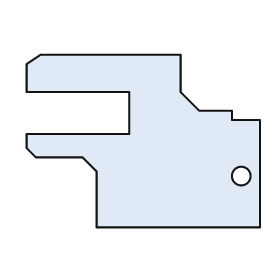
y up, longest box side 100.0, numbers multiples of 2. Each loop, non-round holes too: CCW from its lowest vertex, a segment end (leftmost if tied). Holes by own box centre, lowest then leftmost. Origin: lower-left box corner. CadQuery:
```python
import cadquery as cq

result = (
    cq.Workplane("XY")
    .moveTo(30.0, 0.0)
    .lineTo(100.0, 0.0)
    .lineTo(100.0, 46.0)
    .lineTo(88.0, 46.0)
    .lineTo(88.0, 50.0)
    .lineTo(74.0, 50.0)
    .lineTo(66.0, 58.0)
    .lineTo(66.0, 74.0)
    .lineTo(6.0, 74.0)
    .lineTo(0.0, 70.0)
    .lineTo(0.0, 58.0)
    .lineTo(44.0, 58.0)
    .lineTo(44.0, 40.0)
    .lineTo(0.0, 40.0)
    .lineTo(0.0, 34.0)
    .lineTo(4.0, 30.0)
    .lineTo(24.0, 30.0)
    .lineTo(30.0, 24.0)
    .close()
    .moveTo(92.0, 22.0)
    .circle(4.0)
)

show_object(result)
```